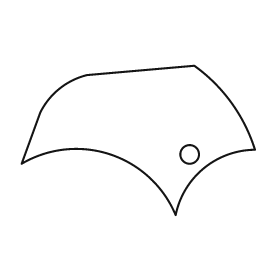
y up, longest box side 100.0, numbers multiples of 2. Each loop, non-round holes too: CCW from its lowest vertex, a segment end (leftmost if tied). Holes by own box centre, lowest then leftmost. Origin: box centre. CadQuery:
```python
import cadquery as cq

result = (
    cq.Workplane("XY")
    .moveTo(16.0, -32.0)
    .threePointArc((28.0, -12.0), (50.0, -4.0))
    .threePointArc((40.0, 16.0), (24.0, 32.0))
    .lineTo(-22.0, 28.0)
    .threePointArc((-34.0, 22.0), (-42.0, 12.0))
    .lineTo(-50.0, -10.0)
    .threePointArc((-12.0, -6.0), (16.0, -32.0))
    .close()
    .moveTo(22.0, -6.0)
    .circle(4.0)
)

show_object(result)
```